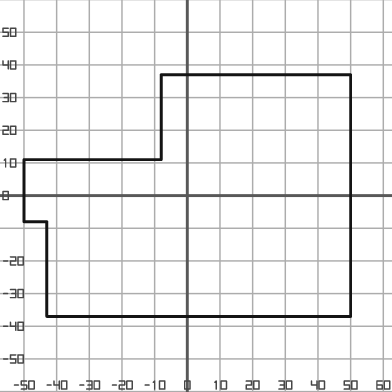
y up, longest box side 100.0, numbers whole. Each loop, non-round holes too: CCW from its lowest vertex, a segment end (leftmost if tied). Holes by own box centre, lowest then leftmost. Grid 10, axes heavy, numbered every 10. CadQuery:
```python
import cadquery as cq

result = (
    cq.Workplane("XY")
    .moveTo(-43.0, -37.0)
    .lineTo(50.0, -37.0)
    .lineTo(50.0, 37.0)
    .lineTo(-8.0, 37.0)
    .lineTo(-8.0, 11.0)
    .lineTo(-50.0, 11.0)
    .lineTo(-50.0, -8.0)
    .lineTo(-43.0, -8.0)
    .close()
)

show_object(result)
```